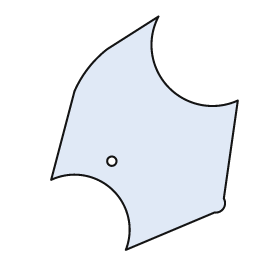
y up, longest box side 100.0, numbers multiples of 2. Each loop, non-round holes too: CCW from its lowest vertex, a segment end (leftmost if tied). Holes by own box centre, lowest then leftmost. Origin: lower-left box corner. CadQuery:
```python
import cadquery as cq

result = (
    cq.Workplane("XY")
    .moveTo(32.0, 0.0)
    .lineTo(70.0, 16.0)
    .threePointArc((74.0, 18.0), (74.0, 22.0))
    .lineTo(80.0, 64.0)
    .threePointArc((50.0, 70.0), (46.0, 100.0))
    .lineTo(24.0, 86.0)
    .threePointArc((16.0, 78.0), (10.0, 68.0))
    .lineTo(0.0, 30.0)
    .threePointArc((26.0, 26.0), (32.0, 0.0))
    .close()
    .moveTo(26.0, 38.0)
    .circle(2.0)
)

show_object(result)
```